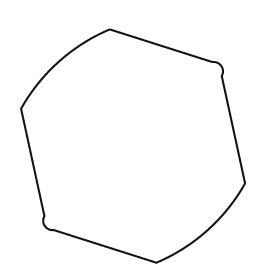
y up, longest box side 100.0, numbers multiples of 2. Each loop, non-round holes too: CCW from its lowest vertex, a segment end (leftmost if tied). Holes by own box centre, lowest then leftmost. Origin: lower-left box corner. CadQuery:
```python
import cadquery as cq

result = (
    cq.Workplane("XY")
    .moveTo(58.0, 0.0)
    .threePointArc((80.0, 14.0), (96.0, 34.0))
    .lineTo(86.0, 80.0)
    .threePointArc((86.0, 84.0), (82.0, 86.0))
    .lineTo(38.0, 100.0)
    .threePointArc((16.0, 86.0), (0.0, 66.0))
    .lineTo(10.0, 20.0)
    .threePointArc((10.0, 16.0), (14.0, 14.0))
    .close()
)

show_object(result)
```